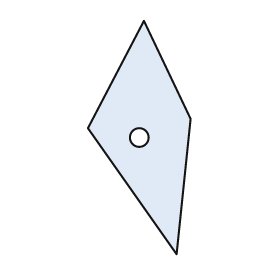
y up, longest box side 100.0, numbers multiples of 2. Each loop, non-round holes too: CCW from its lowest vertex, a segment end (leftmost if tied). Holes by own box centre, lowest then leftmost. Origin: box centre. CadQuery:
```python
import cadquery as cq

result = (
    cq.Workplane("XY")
    .moveTo(16.0, -50.0)
    .lineTo(22.0, 8.0)
    .lineTo(2.0, 50.0)
    .lineTo(-22.0, 4.0)
    .close()
    .moveTo(0.0, 0.0)
    .circle(4.0)
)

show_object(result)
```